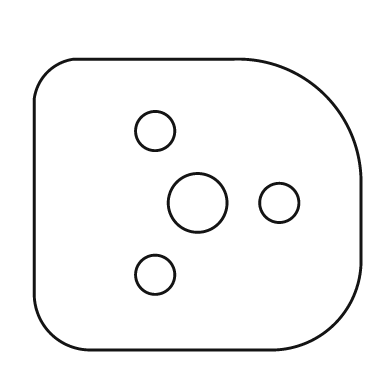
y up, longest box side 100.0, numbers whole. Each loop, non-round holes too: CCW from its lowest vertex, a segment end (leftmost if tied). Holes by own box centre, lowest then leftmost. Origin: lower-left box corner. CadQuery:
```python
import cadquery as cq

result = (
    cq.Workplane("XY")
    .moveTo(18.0, 0.0)
    .lineTo(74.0, 0.0)
    .threePointArc((92.0, 8.0), (100.0, 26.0))
    .lineTo(100.0, 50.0)
    .threePointArc((89.0, 78.0), (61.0, 89.0))
    .lineTo(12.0, 89.0)
    .threePointArc((4.0, 85.0), (0.0, 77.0))
    .lineTo(0.0, 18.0)
    .threePointArc((5.0, 5.0), (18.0, 0.0))
    .close()
    .moveTo(37.0, 23.0)
    .circle(6.0)
    .moveTo(50.0, 45.0)
    .circle(9.0)
    .moveTo(75.0, 45.0)
    .circle(6.0)
    .moveTo(37.0, 67.0)
    .circle(6.0)
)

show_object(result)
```